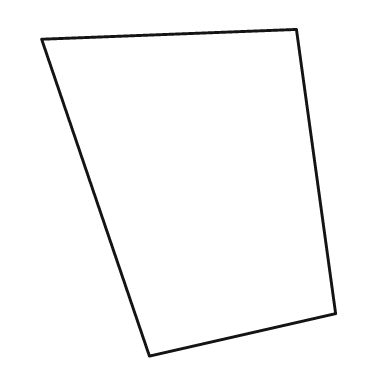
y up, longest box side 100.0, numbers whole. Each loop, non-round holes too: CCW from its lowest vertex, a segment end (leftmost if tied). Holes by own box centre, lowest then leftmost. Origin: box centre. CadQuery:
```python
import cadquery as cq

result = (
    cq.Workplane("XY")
    .moveTo(-12.0, -50.0)
    .lineTo(45.0, -37.0)
    .lineTo(33.0, 50.0)
    .lineTo(-45.0, 47.0)
    .close()
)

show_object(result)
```